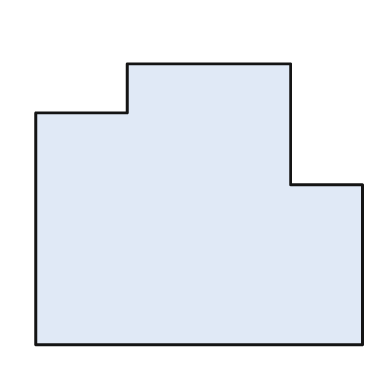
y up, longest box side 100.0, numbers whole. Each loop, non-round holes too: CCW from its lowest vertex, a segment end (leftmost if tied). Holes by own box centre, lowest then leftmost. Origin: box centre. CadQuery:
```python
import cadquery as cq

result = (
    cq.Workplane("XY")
    .moveTo(-50.0, -43.0)
    .lineTo(50.0, -43.0)
    .lineTo(50.0, 6.0)
    .lineTo(28.0, 6.0)
    .lineTo(28.0, 43.0)
    .lineTo(-22.0, 43.0)
    .lineTo(-22.0, 28.0)
    .lineTo(-50.0, 28.0)
    .close()
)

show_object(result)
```